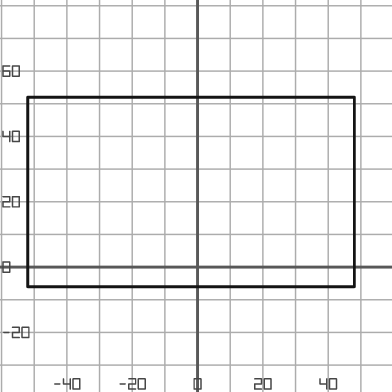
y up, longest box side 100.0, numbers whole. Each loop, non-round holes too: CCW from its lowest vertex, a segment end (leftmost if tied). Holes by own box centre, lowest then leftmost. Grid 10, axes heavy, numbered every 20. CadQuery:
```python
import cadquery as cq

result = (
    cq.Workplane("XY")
    .moveTo(-52.0, -6.0)
    .lineTo(48.0, -6.0)
    .lineTo(48.0, 52.0)
    .lineTo(-52.0, 52.0)
    .close()
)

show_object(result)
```